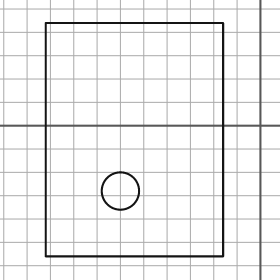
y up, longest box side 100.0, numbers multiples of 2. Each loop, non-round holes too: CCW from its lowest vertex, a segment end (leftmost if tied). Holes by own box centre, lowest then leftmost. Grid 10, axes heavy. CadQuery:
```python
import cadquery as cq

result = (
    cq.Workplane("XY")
    .moveTo(-92.0, -56.0)
    .lineTo(-16.0, -56.0)
    .lineTo(-16.0, 44.0)
    .lineTo(-92.0, 44.0)
    .close()
    .moveTo(-60.0, -28.0)
    .circle(8.0)
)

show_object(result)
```